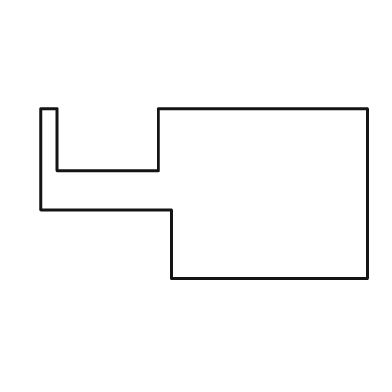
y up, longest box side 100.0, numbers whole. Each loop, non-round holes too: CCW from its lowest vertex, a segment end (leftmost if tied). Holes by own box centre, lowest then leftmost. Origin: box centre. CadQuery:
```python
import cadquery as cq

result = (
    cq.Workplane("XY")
    .moveTo(-10.0, -26.0)
    .lineTo(50.0, -26.0)
    .lineTo(50.0, 26.0)
    .lineTo(-14.0, 26.0)
    .lineTo(-14.0, 7.0)
    .lineTo(-45.0, 7.0)
    .lineTo(-45.0, 26.0)
    .lineTo(-50.0, 26.0)
    .lineTo(-50.0, -5.0)
    .lineTo(-10.0, -5.0)
    .close()
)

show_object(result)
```